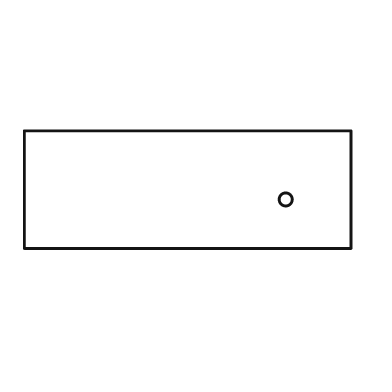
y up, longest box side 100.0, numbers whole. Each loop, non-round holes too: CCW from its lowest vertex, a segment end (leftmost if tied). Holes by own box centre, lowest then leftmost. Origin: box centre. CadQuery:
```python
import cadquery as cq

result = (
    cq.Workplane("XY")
    .moveTo(-50.0, -18.0)
    .lineTo(50.0, -18.0)
    .lineTo(50.0, 18.0)
    .lineTo(-50.0, 18.0)
    .close()
    .moveTo(30.0, -3.0)
    .circle(2.0)
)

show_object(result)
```